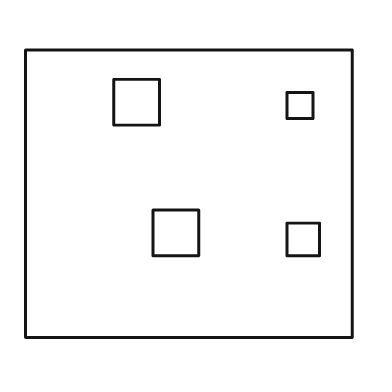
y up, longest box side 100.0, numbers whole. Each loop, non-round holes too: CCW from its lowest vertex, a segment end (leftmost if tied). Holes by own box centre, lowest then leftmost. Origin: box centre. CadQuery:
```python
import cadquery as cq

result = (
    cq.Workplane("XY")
    .moveTo(-50.0, -44.0)
    .lineTo(50.0, -44.0)
    .lineTo(50.0, 44.0)
    .lineTo(-50.0, 44.0)
    .close()
    .moveTo(30.0, -19.0)
    .lineTo(40.0, -19.0)
    .lineTo(40.0, -9.0)
    .lineTo(30.0, -9.0)
    .close()
    .moveTo(-11.0, -19.0)
    .lineTo(3.0, -19.0)
    .lineTo(3.0, -5.0)
    .lineTo(-11.0, -5.0)
    .close()
    .moveTo(30.0, 23.0)
    .lineTo(38.0, 23.0)
    .lineTo(38.0, 31.0)
    .lineTo(30.0, 31.0)
    .close()
    .moveTo(-23.0, 21.0)
    .lineTo(-9.0, 21.0)
    .lineTo(-9.0, 35.0)
    .lineTo(-23.0, 35.0)
    .close()
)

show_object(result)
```